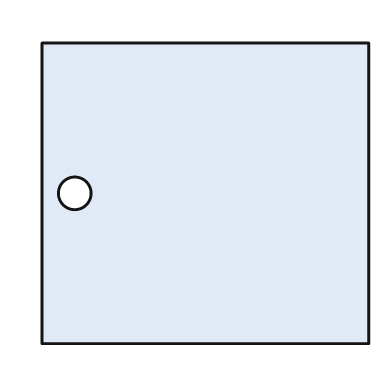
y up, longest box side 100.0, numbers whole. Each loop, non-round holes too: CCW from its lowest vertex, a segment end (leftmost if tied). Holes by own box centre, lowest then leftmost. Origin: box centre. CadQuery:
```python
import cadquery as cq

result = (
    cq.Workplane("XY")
    .moveTo(-50.0, -46.0)
    .lineTo(50.0, -46.0)
    .lineTo(50.0, 46.0)
    .lineTo(-50.0, 46.0)
    .close()
    .moveTo(-40.0, 0.0)
    .circle(5.0)
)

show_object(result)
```